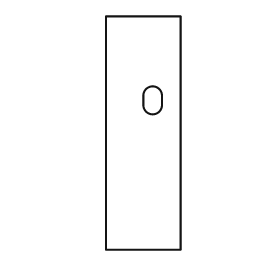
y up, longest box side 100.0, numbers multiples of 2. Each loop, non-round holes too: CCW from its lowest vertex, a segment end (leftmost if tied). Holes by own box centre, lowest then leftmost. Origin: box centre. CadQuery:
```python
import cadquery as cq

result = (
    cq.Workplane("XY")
    .moveTo(-16.0, -50.0)
    .lineTo(16.0, -50.0)
    .lineTo(16.0, 50.0)
    .lineTo(-16.0, 50.0)
    .close()
    .moveTo(0.0, 12.0)
    .threePointArc((4.0, 8.0), (8.0, 12.0))
    .lineTo(8.0, 16.0)
    .threePointArc((4.0, 20.0), (0.0, 16.0))
    .close()
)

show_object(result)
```